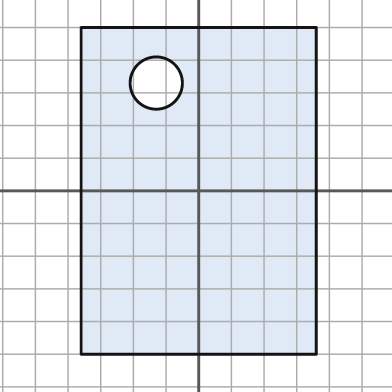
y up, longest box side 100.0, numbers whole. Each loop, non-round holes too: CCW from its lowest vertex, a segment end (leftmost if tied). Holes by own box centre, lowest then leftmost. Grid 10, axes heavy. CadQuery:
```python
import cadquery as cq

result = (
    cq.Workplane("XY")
    .moveTo(-36.0, -50.0)
    .lineTo(36.0, -50.0)
    .lineTo(36.0, 50.0)
    .lineTo(-36.0, 50.0)
    .close()
    .moveTo(-13.0, 33.0)
    .circle(8.0)
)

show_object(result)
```